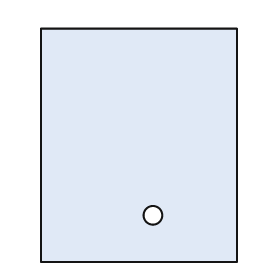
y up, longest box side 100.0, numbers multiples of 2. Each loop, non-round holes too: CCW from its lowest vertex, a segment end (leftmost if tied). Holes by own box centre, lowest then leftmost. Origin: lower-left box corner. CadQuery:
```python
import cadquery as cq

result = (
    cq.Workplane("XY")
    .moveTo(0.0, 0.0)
    .lineTo(84.0, 0.0)
    .lineTo(84.0, 100.0)
    .lineTo(0.0, 100.0)
    .close()
    .moveTo(48.0, 20.0)
    .circle(4.0)
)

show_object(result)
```